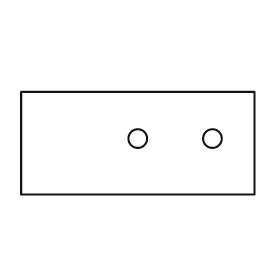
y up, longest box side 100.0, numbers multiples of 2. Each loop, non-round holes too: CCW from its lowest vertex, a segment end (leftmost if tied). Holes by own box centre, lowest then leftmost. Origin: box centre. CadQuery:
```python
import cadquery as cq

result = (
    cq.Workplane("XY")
    .moveTo(-50.0, -22.0)
    .lineTo(50.0, -22.0)
    .lineTo(50.0, 22.0)
    .lineTo(-50.0, 22.0)
    .close()
    .moveTo(0.0, 2.0)
    .circle(4.0)
    .moveTo(32.0, 2.0)
    .circle(4.0)
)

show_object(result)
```